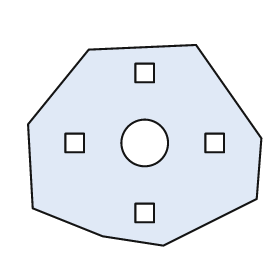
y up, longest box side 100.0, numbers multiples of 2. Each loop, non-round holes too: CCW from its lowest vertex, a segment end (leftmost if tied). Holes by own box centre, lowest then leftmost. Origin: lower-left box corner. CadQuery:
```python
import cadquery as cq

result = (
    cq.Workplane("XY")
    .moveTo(58.0, 0.0)
    .lineTo(98.0, 20.0)
    .lineTo(100.0, 46.0)
    .lineTo(72.0, 86.0)
    .lineTo(26.0, 84.0)
    .lineTo(0.0, 52.0)
    .lineTo(2.0, 16.0)
    .lineTo(32.0, 4.0)
    .close()
    .moveTo(46.0, 10.0)
    .lineTo(54.0, 10.0)
    .lineTo(54.0, 18.0)
    .lineTo(46.0, 18.0)
    .close()
    .moveTo(16.0, 40.0)
    .lineTo(24.0, 40.0)
    .lineTo(24.0, 48.0)
    .lineTo(16.0, 48.0)
    .close()
    .moveTo(50.0, 44.0)
    .circle(10.0)
    .moveTo(76.0, 40.0)
    .lineTo(84.0, 40.0)
    .lineTo(84.0, 48.0)
    .lineTo(76.0, 48.0)
    .close()
    .moveTo(46.0, 70.0)
    .lineTo(54.0, 70.0)
    .lineTo(54.0, 78.0)
    .lineTo(46.0, 78.0)
    .close()
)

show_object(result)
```